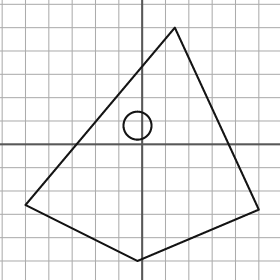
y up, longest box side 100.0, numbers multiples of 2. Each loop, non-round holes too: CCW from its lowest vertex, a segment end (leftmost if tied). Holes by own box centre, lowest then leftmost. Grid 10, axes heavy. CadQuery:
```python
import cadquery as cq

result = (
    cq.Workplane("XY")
    .moveTo(-2.0, -50.0)
    .lineTo(50.0, -28.0)
    .lineTo(14.0, 50.0)
    .lineTo(-50.0, -26.0)
    .close()
    .moveTo(-2.0, 8.0)
    .circle(6.0)
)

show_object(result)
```